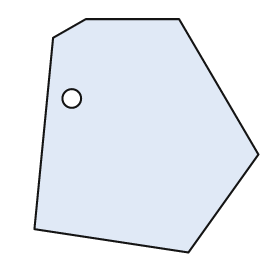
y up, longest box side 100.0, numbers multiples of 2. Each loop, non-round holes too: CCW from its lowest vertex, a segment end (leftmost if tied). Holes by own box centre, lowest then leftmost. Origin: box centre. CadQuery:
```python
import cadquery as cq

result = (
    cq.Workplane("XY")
    .moveTo(18.0, -50.0)
    .lineTo(48.0, -8.0)
    .lineTo(14.0, 50.0)
    .lineTo(-26.0, 50.0)
    .lineTo(-40.0, 42.0)
    .lineTo(-48.0, -40.0)
    .close()
    .moveTo(-32.0, 16.0)
    .circle(4.0)
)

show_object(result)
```